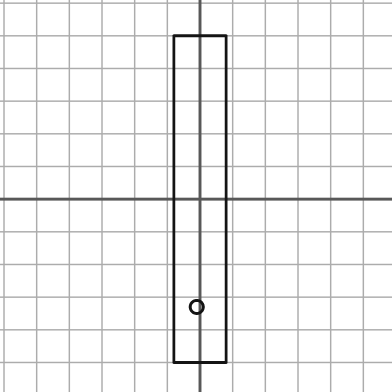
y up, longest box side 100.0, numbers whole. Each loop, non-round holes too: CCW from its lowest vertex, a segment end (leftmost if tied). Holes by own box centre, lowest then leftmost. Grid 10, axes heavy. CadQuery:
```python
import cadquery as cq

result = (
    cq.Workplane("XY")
    .moveTo(-8.0, -50.0)
    .lineTo(8.0, -50.0)
    .lineTo(8.0, 50.0)
    .lineTo(-8.0, 50.0)
    .close()
    .moveTo(-1.0, -33.0)
    .circle(2.0)
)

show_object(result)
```